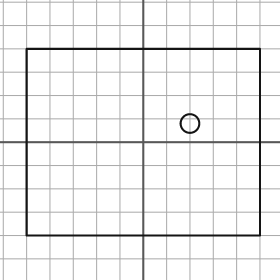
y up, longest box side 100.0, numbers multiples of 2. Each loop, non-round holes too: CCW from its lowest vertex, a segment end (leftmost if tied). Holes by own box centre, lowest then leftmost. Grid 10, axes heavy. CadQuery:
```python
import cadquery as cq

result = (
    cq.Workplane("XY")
    .moveTo(-50.0, -40.0)
    .lineTo(50.0, -40.0)
    .lineTo(50.0, 40.0)
    .lineTo(-50.0, 40.0)
    .close()
    .moveTo(20.0, 8.0)
    .circle(4.0)
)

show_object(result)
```